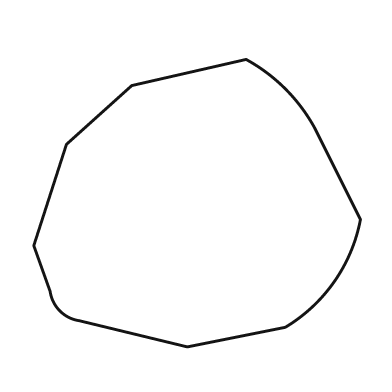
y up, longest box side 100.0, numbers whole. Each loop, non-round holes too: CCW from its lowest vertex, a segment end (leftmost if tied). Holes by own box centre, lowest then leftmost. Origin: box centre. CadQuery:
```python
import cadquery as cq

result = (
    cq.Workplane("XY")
    .moveTo(-3.0, -44.0)
    .lineTo(27.0, -38.0)
    .threePointArc((42.0, -24.0), (50.0, -5.0))
    .lineTo(36.0, 23.0)
    .threePointArc((27.0, 35.0), (15.0, 44.0))
    .lineTo(-20.0, 36.0)
    .lineTo(-40.0, 18.0)
    .lineTo(-50.0, -13.0)
    .lineTo(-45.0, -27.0)
    .threePointArc((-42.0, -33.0), (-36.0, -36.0))
    .close()
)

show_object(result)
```